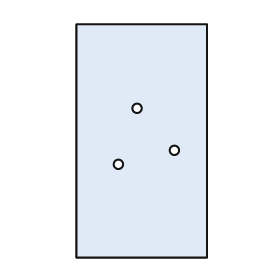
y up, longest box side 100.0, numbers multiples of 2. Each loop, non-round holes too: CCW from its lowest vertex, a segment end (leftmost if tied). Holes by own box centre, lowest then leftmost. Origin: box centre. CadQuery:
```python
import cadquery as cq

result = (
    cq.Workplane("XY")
    .moveTo(-28.0, -50.0)
    .lineTo(28.0, -50.0)
    .lineTo(28.0, 50.0)
    .lineTo(-28.0, 50.0)
    .close()
    .moveTo(-10.0, -10.0)
    .circle(2.0)
    .moveTo(14.0, -4.0)
    .circle(2.0)
    .moveTo(-2.0, 14.0)
    .circle(2.0)
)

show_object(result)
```